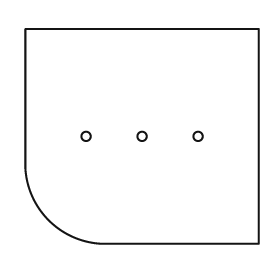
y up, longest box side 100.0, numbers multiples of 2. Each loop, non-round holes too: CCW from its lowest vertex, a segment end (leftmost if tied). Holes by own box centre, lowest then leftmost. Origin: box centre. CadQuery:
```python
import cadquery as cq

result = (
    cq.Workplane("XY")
    .moveTo(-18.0, -46.0)
    .lineTo(50.0, -46.0)
    .lineTo(50.0, 46.0)
    .lineTo(-50.0, 46.0)
    .lineTo(-50.0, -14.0)
    .threePointArc((-40.0, -36.0), (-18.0, -46.0))
    .close()
    .moveTo(-24.0, 0.0)
    .circle(2.0)
    .moveTo(0.0, 0.0)
    .circle(2.0)
    .moveTo(24.0, 0.0)
    .circle(2.0)
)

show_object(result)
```